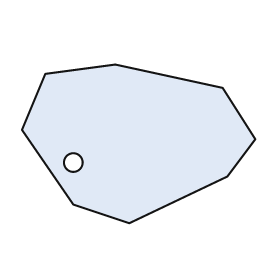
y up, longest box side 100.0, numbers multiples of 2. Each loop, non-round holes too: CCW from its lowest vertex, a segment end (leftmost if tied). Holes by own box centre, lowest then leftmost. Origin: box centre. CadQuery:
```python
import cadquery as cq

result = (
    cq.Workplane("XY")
    .moveTo(-4.0, -34.0)
    .lineTo(38.0, -14.0)
    .lineTo(50.0, 2.0)
    .lineTo(36.0, 24.0)
    .lineTo(-10.0, 34.0)
    .lineTo(-40.0, 30.0)
    .lineTo(-50.0, 6.0)
    .lineTo(-28.0, -26.0)
    .close()
    .moveTo(-28.0, -8.0)
    .circle(4.0)
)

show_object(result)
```